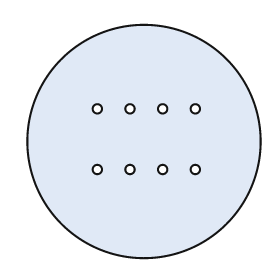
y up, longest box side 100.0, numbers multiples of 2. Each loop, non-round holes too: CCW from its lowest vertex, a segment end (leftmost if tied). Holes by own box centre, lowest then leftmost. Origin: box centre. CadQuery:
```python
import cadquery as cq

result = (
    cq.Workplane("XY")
    .moveTo(0.0, 0.0)
    .circle(50.0)
    .moveTo(-20.0, -12.0)
    .circle(2.0)
    .moveTo(-6.0, -12.0)
    .circle(2.0)
    .moveTo(8.0, -12.0)
    .circle(2.0)
    .moveTo(22.0, -12.0)
    .circle(2.0)
    .moveTo(-20.0, 14.0)
    .circle(2.0)
    .moveTo(-6.0, 14.0)
    .circle(2.0)
    .moveTo(8.0, 14.0)
    .circle(2.0)
    .moveTo(22.0, 14.0)
    .circle(2.0)
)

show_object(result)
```